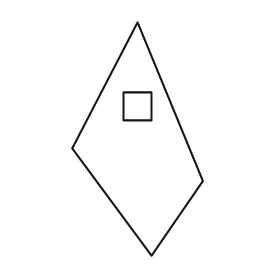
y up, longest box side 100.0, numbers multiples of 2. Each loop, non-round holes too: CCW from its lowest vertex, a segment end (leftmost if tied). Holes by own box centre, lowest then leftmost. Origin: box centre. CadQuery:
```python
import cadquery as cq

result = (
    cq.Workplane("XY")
    .moveTo(6.0, -50.0)
    .lineTo(28.0, -18.0)
    .lineTo(0.0, 50.0)
    .lineTo(-28.0, -4.0)
    .close()
    .moveTo(-6.0, 8.0)
    .lineTo(6.0, 8.0)
    .lineTo(6.0, 20.0)
    .lineTo(-6.0, 20.0)
    .close()
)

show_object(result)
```